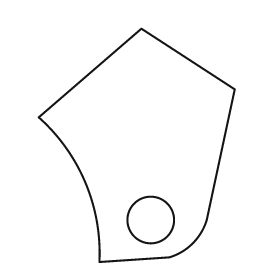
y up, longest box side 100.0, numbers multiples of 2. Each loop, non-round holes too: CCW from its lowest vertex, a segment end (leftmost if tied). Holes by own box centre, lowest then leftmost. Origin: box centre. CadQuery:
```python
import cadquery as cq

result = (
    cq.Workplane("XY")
    .moveTo(-16.0, -50.0)
    .lineTo(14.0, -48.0)
    .threePointArc((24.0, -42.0), (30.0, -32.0))
    .lineTo(42.0, 24.0)
    .lineTo(2.0, 50.0)
    .lineTo(-42.0, 12.0)
    .threePointArc((-22.0, -16.0), (-16.0, -50.0))
    .close()
    .moveTo(6.0, -32.0)
    .circle(10.0)
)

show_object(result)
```